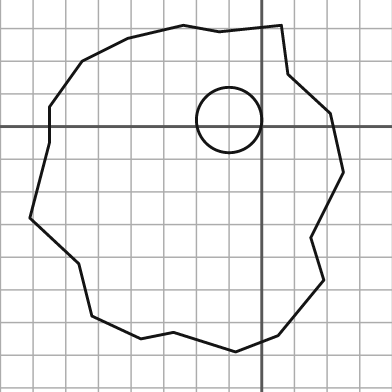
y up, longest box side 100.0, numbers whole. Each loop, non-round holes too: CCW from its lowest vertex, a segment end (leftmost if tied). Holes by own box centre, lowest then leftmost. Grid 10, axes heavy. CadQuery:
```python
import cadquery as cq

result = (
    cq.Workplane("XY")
    .moveTo(-8.0, -69.0)
    .lineTo(5.0, -64.0)
    .lineTo(19.0, -47.0)
    .lineTo(15.0, -34.0)
    .lineTo(25.0, -14.0)
    .lineTo(21.0, 4.0)
    .lineTo(8.0, 16.0)
    .lineTo(6.0, 31.0)
    .lineTo(-13.0, 29.0)
    .lineTo(-24.0, 31.0)
    .lineTo(-41.0, 27.0)
    .lineTo(-55.0, 20.0)
    .lineTo(-65.0, 6.0)
    .lineTo(-65.0, -5.0)
    .lineTo(-71.0, -28.0)
    .lineTo(-56.0, -42.0)
    .lineTo(-52.0, -58.0)
    .lineTo(-37.0, -65.0)
    .lineTo(-27.0, -63.0)
    .close()
    .moveTo(-10.0, 2.0)
    .circle(10.0)
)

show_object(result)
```